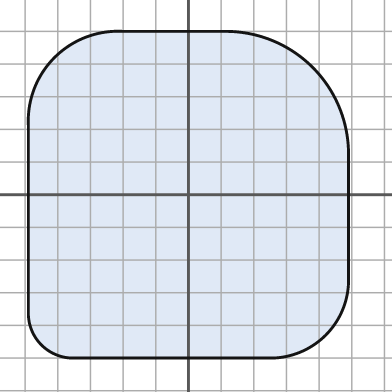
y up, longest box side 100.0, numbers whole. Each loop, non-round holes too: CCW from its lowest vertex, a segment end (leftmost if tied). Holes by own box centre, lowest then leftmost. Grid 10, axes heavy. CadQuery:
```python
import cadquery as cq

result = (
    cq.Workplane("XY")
    .moveTo(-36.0, -50.0)
    .lineTo(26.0, -50.0)
    .threePointArc((42.0, -43.0), (49.0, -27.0))
    .lineTo(49.0, 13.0)
    .threePointArc((38.0, 39.0), (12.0, 50.0))
    .lineTo(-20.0, 50.0)
    .threePointArc((-41.0, 42.0), (-49.0, 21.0))
    .lineTo(-49.0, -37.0)
    .threePointArc((-45.0, -46.0), (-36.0, -50.0))
    .close()
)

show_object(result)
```